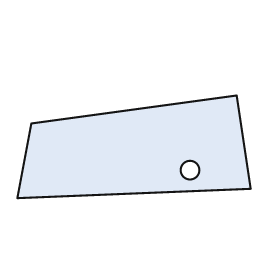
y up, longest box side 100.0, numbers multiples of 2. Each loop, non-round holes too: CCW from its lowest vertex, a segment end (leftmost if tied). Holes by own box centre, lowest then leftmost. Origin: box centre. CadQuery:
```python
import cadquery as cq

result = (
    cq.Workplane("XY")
    .moveTo(-50.0, -22.0)
    .lineTo(50.0, -18.0)
    .lineTo(44.0, 22.0)
    .lineTo(-44.0, 10.0)
    .close()
    .moveTo(24.0, -10.0)
    .circle(4.0)
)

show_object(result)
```